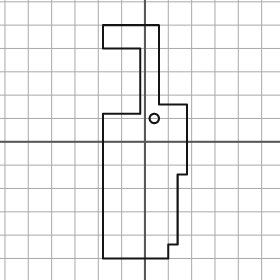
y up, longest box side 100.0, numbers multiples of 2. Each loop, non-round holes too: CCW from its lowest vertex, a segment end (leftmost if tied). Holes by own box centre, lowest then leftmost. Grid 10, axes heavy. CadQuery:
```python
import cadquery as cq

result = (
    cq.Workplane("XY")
    .moveTo(-18.0, -50.0)
    .lineTo(10.0, -50.0)
    .lineTo(10.0, -44.0)
    .lineTo(14.0, -44.0)
    .lineTo(14.0, -14.0)
    .lineTo(18.0, -14.0)
    .lineTo(18.0, 16.0)
    .lineTo(6.0, 16.0)
    .lineTo(6.0, 50.0)
    .lineTo(-18.0, 50.0)
    .lineTo(-18.0, 40.0)
    .lineTo(-2.0, 40.0)
    .lineTo(-2.0, 12.0)
    .lineTo(-18.0, 12.0)
    .close()
    .moveTo(4.0, 10.0)
    .circle(2.0)
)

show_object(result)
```